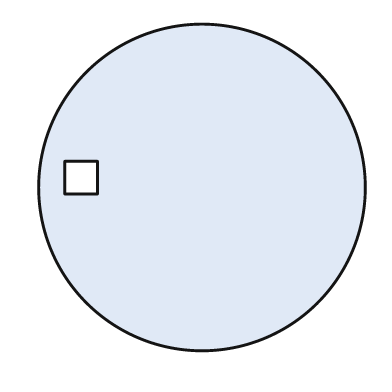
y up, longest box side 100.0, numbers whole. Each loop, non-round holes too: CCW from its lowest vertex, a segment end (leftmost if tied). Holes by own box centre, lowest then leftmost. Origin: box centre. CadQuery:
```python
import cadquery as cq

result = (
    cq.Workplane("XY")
    .moveTo(0.0, 0.0)
    .circle(50.0)
    .moveTo(-42.0, -2.0)
    .lineTo(-32.0, -2.0)
    .lineTo(-32.0, 8.0)
    .lineTo(-42.0, 8.0)
    .close()
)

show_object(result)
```